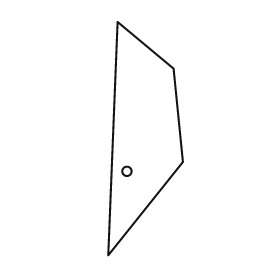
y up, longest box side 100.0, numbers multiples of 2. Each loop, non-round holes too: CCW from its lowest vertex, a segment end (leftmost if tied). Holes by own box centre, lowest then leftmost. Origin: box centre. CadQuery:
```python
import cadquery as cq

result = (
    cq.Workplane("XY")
    .moveTo(-16.0, -50.0)
    .lineTo(16.0, -10.0)
    .lineTo(12.0, 30.0)
    .lineTo(-12.0, 50.0)
    .close()
    .moveTo(-8.0, -14.0)
    .circle(2.0)
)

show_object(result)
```